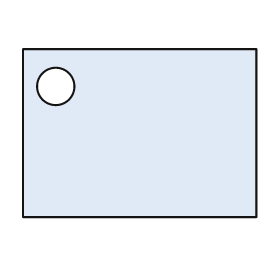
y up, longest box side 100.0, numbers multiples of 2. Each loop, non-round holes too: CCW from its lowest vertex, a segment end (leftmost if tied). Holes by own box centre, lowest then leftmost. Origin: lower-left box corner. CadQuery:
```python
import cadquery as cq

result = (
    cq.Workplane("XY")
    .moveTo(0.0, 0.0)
    .lineTo(100.0, 0.0)
    .lineTo(100.0, 72.0)
    .lineTo(0.0, 72.0)
    .close()
    .moveTo(14.0, 56.0)
    .circle(8.0)
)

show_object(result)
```